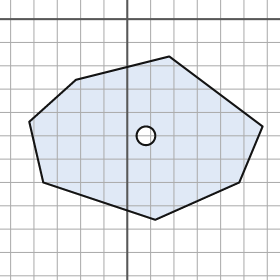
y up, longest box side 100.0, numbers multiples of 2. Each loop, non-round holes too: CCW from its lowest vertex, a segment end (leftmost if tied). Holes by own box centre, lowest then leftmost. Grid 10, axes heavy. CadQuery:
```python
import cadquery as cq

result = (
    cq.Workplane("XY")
    .moveTo(12.0, -86.0)
    .lineTo(48.0, -70.0)
    .lineTo(58.0, -46.0)
    .lineTo(18.0, -16.0)
    .lineTo(-22.0, -26.0)
    .lineTo(-42.0, -44.0)
    .lineTo(-36.0, -70.0)
    .close()
    .moveTo(8.0, -50.0)
    .circle(4.0)
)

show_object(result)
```